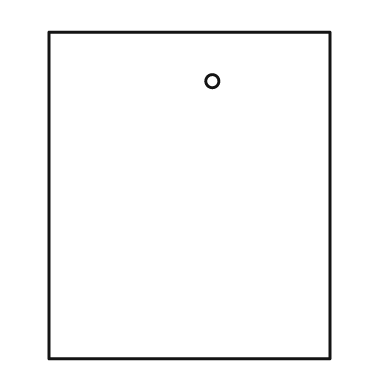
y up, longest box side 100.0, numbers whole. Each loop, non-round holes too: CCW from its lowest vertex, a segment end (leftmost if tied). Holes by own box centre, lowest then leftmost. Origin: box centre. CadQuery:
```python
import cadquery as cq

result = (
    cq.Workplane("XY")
    .moveTo(-43.0, -50.0)
    .lineTo(43.0, -50.0)
    .lineTo(43.0, 50.0)
    .lineTo(-43.0, 50.0)
    .close()
    .moveTo(7.0, 35.0)
    .circle(2.0)
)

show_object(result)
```